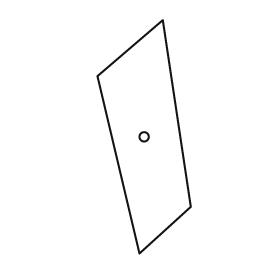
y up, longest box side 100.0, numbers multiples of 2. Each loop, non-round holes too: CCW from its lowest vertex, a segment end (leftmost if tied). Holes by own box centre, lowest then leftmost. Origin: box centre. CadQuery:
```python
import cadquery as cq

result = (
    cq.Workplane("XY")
    .moveTo(-2.0, -50.0)
    .lineTo(20.0, -30.0)
    .lineTo(8.0, 50.0)
    .lineTo(-20.0, 26.0)
    .close()
    .moveTo(0.0, 0.0)
    .circle(2.0)
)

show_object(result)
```